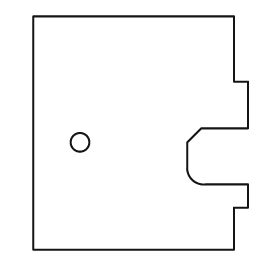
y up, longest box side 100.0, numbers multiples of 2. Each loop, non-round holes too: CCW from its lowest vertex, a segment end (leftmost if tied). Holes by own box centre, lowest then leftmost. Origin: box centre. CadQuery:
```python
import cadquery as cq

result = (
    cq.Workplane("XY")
    .moveTo(-46.0, -50.0)
    .lineTo(40.0, -50.0)
    .lineTo(40.0, -32.0)
    .lineTo(46.0, -32.0)
    .lineTo(46.0, -22.0)
    .lineTo(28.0, -22.0)
    .threePointArc((22.0, -20.0), (20.0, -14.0))
    .lineTo(20.0, -4.0)
    .lineTo(26.0, 2.0)
    .lineTo(46.0, 2.0)
    .lineTo(46.0, 22.0)
    .lineTo(40.0, 22.0)
    .lineTo(40.0, 50.0)
    .lineTo(-46.0, 50.0)
    .close()
    .moveTo(-26.0, -4.0)
    .circle(4.0)
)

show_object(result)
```